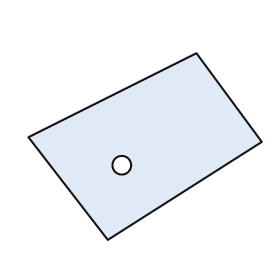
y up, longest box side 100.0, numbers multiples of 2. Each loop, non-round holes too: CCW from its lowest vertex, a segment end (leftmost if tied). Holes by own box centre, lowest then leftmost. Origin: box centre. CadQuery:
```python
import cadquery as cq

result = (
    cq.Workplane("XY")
    .moveTo(-16.0, -40.0)
    .lineTo(50.0, 2.0)
    .lineTo(22.0, 40.0)
    .lineTo(-50.0, 4.0)
    .close()
    .moveTo(-10.0, -8.0)
    .circle(4.0)
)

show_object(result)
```